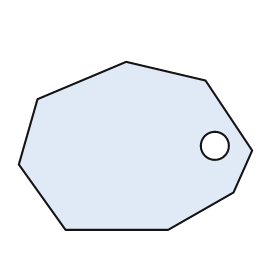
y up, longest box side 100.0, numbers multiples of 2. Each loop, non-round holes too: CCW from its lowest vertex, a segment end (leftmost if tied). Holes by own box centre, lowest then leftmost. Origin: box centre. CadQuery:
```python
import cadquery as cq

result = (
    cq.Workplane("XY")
    .moveTo(-30.0, -36.0)
    .lineTo(14.0, -36.0)
    .lineTo(42.0, -20.0)
    .lineTo(50.0, -2.0)
    .lineTo(30.0, 28.0)
    .lineTo(-4.0, 36.0)
    .lineTo(-42.0, 20.0)
    .lineTo(-50.0, -8.0)
    .close()
    .moveTo(34.0, 0.0)
    .circle(6.0)
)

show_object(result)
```